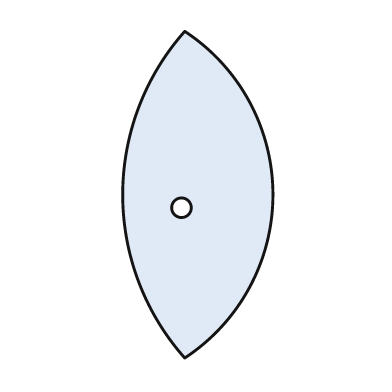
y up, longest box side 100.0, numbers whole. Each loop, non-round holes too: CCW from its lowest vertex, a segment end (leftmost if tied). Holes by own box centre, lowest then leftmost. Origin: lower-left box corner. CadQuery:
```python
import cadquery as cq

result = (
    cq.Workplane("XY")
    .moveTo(19.0, 0.0)
    .threePointArc((46.0, 50.0), (19.0, 100.0))
    .threePointArc((0.0, 50.0), (19.0, 0.0))
    .close()
    .moveTo(18.0, 46.0)
    .circle(3.0)
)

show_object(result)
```